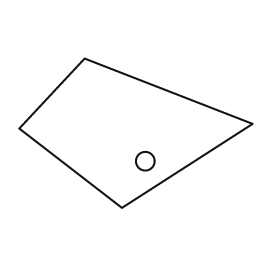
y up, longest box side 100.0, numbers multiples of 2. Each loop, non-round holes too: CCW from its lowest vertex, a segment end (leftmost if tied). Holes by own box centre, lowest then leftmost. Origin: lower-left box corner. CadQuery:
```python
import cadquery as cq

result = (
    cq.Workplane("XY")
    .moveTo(44.0, 0.0)
    .lineTo(100.0, 36.0)
    .lineTo(28.0, 64.0)
    .lineTo(0.0, 34.0)
    .close()
    .moveTo(54.0, 20.0)
    .circle(4.0)
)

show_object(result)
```